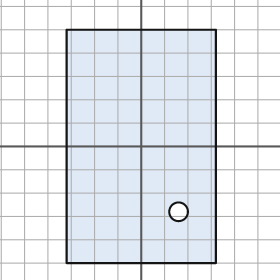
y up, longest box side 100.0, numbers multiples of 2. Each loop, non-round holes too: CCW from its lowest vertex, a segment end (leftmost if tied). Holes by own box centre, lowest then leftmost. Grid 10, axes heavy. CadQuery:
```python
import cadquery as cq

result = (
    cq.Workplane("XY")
    .moveTo(-32.0, -50.0)
    .lineTo(32.0, -50.0)
    .lineTo(32.0, 50.0)
    .lineTo(-32.0, 50.0)
    .close()
    .moveTo(16.0, -28.0)
    .circle(4.0)
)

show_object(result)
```